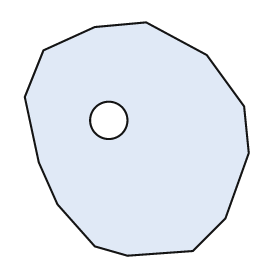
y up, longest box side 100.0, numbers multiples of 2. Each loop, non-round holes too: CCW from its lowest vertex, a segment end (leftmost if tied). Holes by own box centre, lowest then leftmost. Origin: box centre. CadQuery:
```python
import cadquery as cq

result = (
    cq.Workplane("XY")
    .moveTo(-4.0, -50.0)
    .lineTo(24.0, -48.0)
    .lineTo(38.0, -34.0)
    .lineTo(48.0, -6.0)
    .lineTo(46.0, 14.0)
    .lineTo(30.0, 36.0)
    .lineTo(4.0, 50.0)
    .lineTo(-18.0, 48.0)
    .lineTo(-40.0, 38.0)
    .lineTo(-48.0, 18.0)
    .lineTo(-42.0, -10.0)
    .lineTo(-34.0, -28.0)
    .lineTo(-18.0, -46.0)
    .close()
    .moveTo(-12.0, 8.0)
    .circle(8.0)
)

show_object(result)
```